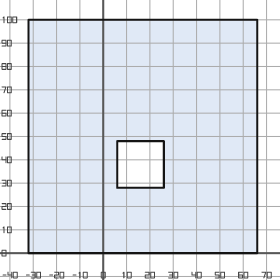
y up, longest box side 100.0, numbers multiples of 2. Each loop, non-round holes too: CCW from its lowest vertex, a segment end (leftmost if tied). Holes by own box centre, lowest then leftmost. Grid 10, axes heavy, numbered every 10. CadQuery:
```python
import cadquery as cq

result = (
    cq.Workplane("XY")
    .moveTo(-32.0, 0.0)
    .lineTo(66.0, 0.0)
    .lineTo(66.0, 100.0)
    .lineTo(-32.0, 100.0)
    .close()
    .moveTo(6.0, 28.0)
    .lineTo(26.0, 28.0)
    .lineTo(26.0, 48.0)
    .lineTo(6.0, 48.0)
    .close()
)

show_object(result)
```